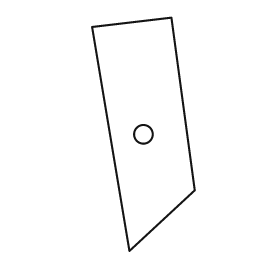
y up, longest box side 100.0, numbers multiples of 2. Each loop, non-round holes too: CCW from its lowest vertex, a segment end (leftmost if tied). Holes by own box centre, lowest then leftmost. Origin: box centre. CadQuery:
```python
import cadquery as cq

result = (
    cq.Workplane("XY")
    .moveTo(-6.0, -50.0)
    .lineTo(22.0, -24.0)
    .lineTo(12.0, 50.0)
    .lineTo(-22.0, 46.0)
    .close()
    .moveTo(0.0, 0.0)
    .circle(4.0)
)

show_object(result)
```